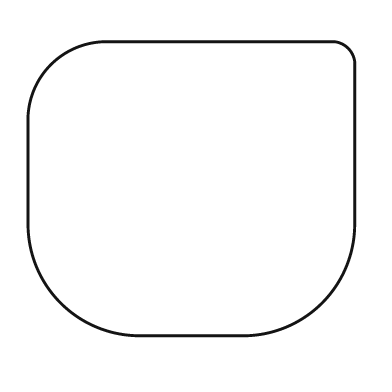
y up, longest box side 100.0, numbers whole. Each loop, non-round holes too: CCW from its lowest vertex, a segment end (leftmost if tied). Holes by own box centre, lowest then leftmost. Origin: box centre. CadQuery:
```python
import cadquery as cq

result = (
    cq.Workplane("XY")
    .moveTo(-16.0, -45.0)
    .lineTo(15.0, -45.0)
    .threePointArc((40.0, -35.0), (50.0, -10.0))
    .lineTo(50.0, 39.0)
    .threePointArc((48.0, 43.0), (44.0, 45.0))
    .lineTo(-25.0, 45.0)
    .threePointArc((-43.0, 38.0), (-50.0, 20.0))
    .lineTo(-50.0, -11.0)
    .threePointArc((-40.0, -35.0), (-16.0, -45.0))
    .close()
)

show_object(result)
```